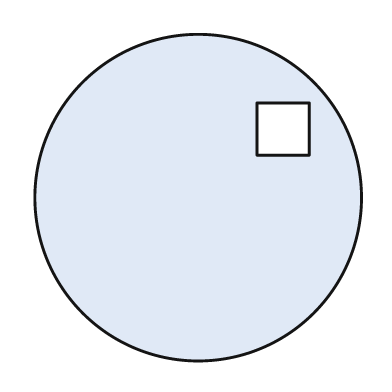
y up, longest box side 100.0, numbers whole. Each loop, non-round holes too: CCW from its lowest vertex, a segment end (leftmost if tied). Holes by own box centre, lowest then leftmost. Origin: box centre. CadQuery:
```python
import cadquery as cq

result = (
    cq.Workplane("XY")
    .moveTo(0.0, 0.0)
    .circle(50.0)
    .moveTo(18.0, 13.0)
    .lineTo(34.0, 13.0)
    .lineTo(34.0, 29.0)
    .lineTo(18.0, 29.0)
    .close()
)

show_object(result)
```